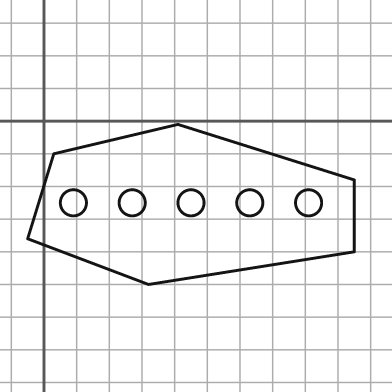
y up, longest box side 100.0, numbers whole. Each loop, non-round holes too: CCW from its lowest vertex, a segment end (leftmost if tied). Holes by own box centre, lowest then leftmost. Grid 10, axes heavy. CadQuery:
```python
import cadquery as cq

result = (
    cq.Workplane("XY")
    .moveTo(32.0, -50.0)
    .lineTo(95.0, -40.0)
    .lineTo(95.0, -18.0)
    .lineTo(41.0, -1.0)
    .lineTo(3.0, -10.0)
    .lineTo(-5.0, -36.0)
    .close()
    .moveTo(9.0, -25.0)
    .circle(4.0)
    .moveTo(27.0, -25.0)
    .circle(4.0)
    .moveTo(45.0, -25.0)
    .circle(4.0)
    .moveTo(63.0, -25.0)
    .circle(4.0)
    .moveTo(81.0, -25.0)
    .circle(4.0)
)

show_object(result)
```